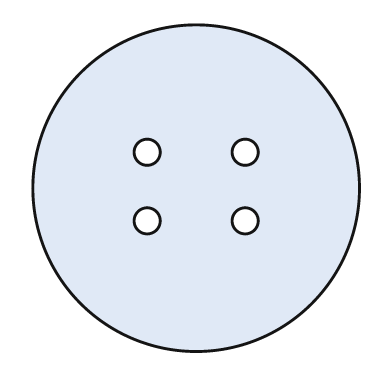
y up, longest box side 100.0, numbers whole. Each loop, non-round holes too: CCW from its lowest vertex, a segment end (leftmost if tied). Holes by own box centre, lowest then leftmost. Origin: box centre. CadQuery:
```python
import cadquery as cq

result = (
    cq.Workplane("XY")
    .moveTo(0.0, 0.0)
    .circle(50.0)
    .moveTo(-15.0, -10.0)
    .circle(4.0)
    .moveTo(15.0, -10.0)
    .circle(4.0)
    .moveTo(-15.0, 11.0)
    .circle(4.0)
    .moveTo(15.0, 11.0)
    .circle(4.0)
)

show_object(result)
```